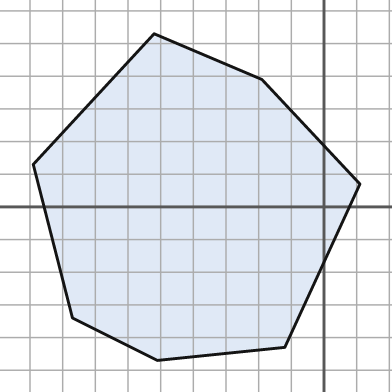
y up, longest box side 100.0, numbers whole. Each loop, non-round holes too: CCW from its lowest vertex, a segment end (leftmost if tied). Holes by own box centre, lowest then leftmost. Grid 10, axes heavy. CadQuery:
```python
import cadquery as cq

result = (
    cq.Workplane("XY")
    .moveTo(-51.0, -47.0)
    .lineTo(-12.0, -43.0)
    .lineTo(11.0, 7.0)
    .lineTo(-19.0, 39.0)
    .lineTo(-52.0, 53.0)
    .lineTo(-89.0, 13.0)
    .lineTo(-77.0, -34.0)
    .close()
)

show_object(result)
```